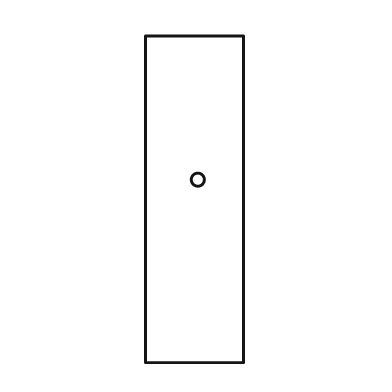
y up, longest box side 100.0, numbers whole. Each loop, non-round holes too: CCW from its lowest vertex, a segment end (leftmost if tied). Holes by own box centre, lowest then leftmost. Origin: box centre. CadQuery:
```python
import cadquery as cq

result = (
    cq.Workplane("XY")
    .moveTo(-15.0, -50.0)
    .lineTo(15.0, -50.0)
    .lineTo(15.0, 50.0)
    .lineTo(-15.0, 50.0)
    .close()
    .moveTo(1.0, 6.0)
    .circle(2.0)
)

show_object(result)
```